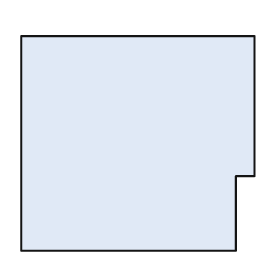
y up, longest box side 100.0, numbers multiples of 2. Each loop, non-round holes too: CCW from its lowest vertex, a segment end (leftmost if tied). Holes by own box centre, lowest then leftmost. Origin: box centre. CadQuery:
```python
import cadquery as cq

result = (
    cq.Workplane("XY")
    .moveTo(-50.0, -46.0)
    .lineTo(42.0, -46.0)
    .lineTo(42.0, -14.0)
    .lineTo(50.0, -14.0)
    .lineTo(50.0, 46.0)
    .lineTo(-50.0, 46.0)
    .close()
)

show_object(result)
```